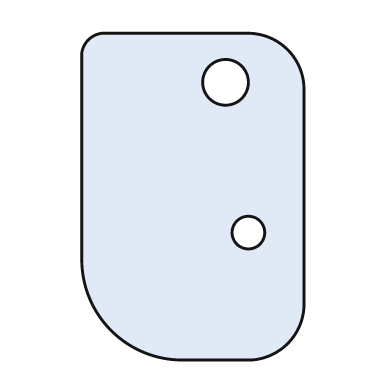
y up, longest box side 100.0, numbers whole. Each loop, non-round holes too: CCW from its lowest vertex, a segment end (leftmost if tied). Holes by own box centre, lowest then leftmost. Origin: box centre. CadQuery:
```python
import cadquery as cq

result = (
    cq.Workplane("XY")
    .moveTo(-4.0, -50.0)
    .lineTo(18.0, -50.0)
    .threePointArc((29.0, -45.0), (34.0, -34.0))
    .lineTo(34.0, 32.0)
    .threePointArc((29.0, 45.0), (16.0, 50.0))
    .lineTo(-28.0, 50.0)
    .threePointArc((-32.0, 48.0), (-34.0, 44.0))
    .lineTo(-34.0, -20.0)
    .threePointArc((-25.0, -41.0), (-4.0, -50.0))
    .close()
    .moveTo(17.0, -11.0)
    .circle(5.0)
    .moveTo(10.0, 35.0)
    .circle(7.0)
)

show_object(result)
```